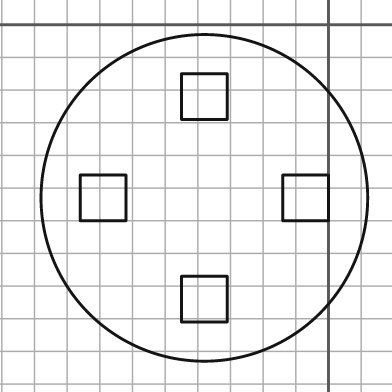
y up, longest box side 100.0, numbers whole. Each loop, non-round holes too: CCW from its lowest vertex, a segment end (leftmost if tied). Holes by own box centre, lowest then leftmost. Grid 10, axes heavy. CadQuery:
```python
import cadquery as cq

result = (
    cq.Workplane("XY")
    .moveTo(-38.0, -53.0)
    .circle(50.0)
    .moveTo(-45.0, -91.0)
    .lineTo(-31.0, -91.0)
    .lineTo(-31.0, -77.0)
    .lineTo(-45.0, -77.0)
    .close()
    .moveTo(-76.0, -60.0)
    .lineTo(-62.0, -60.0)
    .lineTo(-62.0, -46.0)
    .lineTo(-76.0, -46.0)
    .close()
    .moveTo(-14.0, -60.0)
    .lineTo(0.0, -60.0)
    .lineTo(0.0, -46.0)
    .lineTo(-14.0, -46.0)
    .close()
    .moveTo(-45.0, -29.0)
    .lineTo(-31.0, -29.0)
    .lineTo(-31.0, -15.0)
    .lineTo(-45.0, -15.0)
    .close()
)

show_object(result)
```